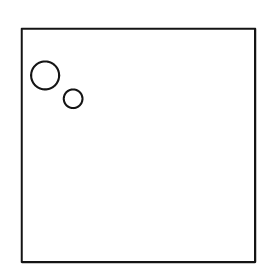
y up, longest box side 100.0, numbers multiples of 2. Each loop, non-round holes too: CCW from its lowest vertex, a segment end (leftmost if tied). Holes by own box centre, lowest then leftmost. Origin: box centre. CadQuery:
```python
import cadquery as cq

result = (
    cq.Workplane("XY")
    .moveTo(-50.0, -50.0)
    .lineTo(50.0, -50.0)
    .lineTo(50.0, 50.0)
    .lineTo(-50.0, 50.0)
    .close()
    .moveTo(-28.0, 20.0)
    .circle(4.0)
    .moveTo(-40.0, 30.0)
    .circle(6.0)
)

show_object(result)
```